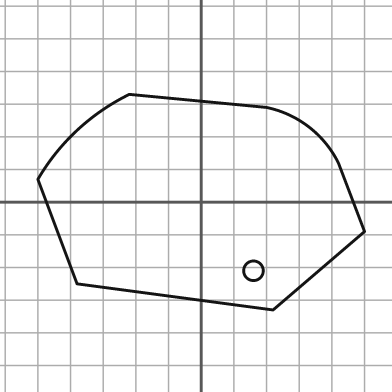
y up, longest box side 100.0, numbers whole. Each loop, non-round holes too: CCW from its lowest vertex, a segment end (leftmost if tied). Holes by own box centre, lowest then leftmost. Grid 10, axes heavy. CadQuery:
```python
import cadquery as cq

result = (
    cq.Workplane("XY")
    .moveTo(22.0, -33.0)
    .lineTo(50.0, -9.0)
    .lineTo(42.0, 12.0)
    .threePointArc((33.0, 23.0), (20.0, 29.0))
    .lineTo(-22.0, 33.0)
    .threePointArc((-38.0, 22.0), (-50.0, 7.0))
    .lineTo(-38.0, -25.0)
    .close()
    .moveTo(16.0, -21.0)
    .circle(3.0)
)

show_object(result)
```